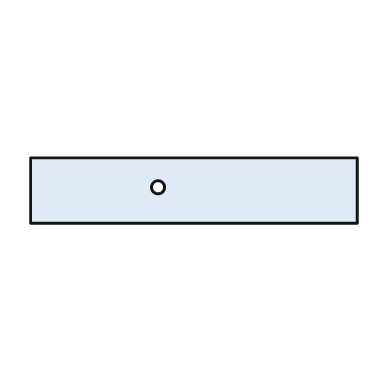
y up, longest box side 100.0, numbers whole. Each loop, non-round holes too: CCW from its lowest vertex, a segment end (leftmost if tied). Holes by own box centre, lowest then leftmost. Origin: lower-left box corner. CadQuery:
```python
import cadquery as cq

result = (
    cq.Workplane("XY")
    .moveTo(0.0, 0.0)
    .lineTo(100.0, 0.0)
    .lineTo(100.0, 20.0)
    .lineTo(0.0, 20.0)
    .close()
    .moveTo(39.0, 11.0)
    .circle(2.0)
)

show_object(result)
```